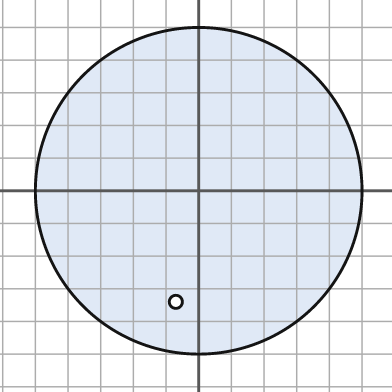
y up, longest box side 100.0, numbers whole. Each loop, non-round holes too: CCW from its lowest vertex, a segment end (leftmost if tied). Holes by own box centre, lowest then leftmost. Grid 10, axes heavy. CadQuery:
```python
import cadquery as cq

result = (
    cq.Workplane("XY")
    .moveTo(0.0, 0.0)
    .circle(50.0)
    .moveTo(-7.0, -34.0)
    .circle(2.0)
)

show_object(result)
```